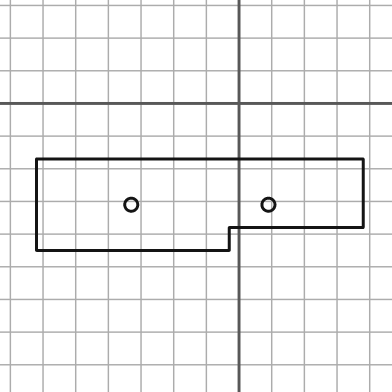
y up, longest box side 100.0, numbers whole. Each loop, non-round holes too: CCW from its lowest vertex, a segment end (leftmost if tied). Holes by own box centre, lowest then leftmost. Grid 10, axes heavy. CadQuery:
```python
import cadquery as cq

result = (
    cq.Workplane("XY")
    .moveTo(-62.0, -45.0)
    .lineTo(-3.0, -45.0)
    .lineTo(-3.0, -38.0)
    .lineTo(38.0, -38.0)
    .lineTo(38.0, -17.0)
    .lineTo(-62.0, -17.0)
    .close()
    .moveTo(-33.0, -31.0)
    .circle(2.0)
    .moveTo(9.0, -31.0)
    .circle(2.0)
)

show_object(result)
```